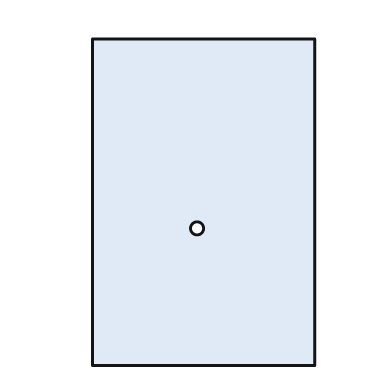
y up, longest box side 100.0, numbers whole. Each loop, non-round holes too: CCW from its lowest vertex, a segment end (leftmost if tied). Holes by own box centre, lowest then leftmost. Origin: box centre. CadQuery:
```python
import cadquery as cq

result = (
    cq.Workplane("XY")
    .moveTo(-34.0, -50.0)
    .lineTo(34.0, -50.0)
    .lineTo(34.0, 50.0)
    .lineTo(-34.0, 50.0)
    .close()
    .moveTo(-2.0, -8.0)
    .circle(2.0)
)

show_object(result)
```